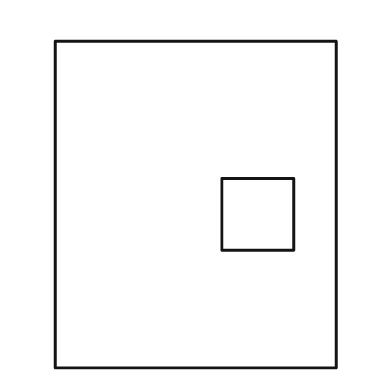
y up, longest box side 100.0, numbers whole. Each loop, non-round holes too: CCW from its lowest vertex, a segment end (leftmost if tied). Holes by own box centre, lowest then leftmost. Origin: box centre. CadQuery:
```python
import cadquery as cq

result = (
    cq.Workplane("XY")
    .moveTo(-43.0, -50.0)
    .lineTo(43.0, -50.0)
    .lineTo(43.0, 50.0)
    .lineTo(-43.0, 50.0)
    .close()
    .moveTo(8.0, -14.0)
    .lineTo(30.0, -14.0)
    .lineTo(30.0, 8.0)
    .lineTo(8.0, 8.0)
    .close()
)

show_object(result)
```